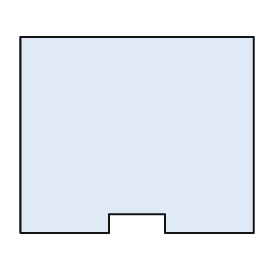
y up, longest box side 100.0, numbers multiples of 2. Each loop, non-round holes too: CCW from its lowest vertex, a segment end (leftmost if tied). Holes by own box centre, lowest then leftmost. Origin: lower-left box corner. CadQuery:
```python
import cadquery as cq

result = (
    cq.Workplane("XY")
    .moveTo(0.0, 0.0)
    .lineTo(38.0, 0.0)
    .lineTo(38.0, 8.0)
    .lineTo(62.0, 8.0)
    .lineTo(62.0, 0.0)
    .lineTo(100.0, 0.0)
    .lineTo(100.0, 84.0)
    .lineTo(0.0, 84.0)
    .close()
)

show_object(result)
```